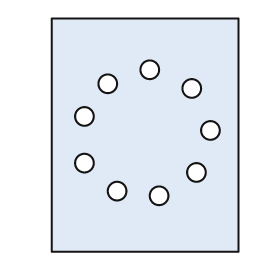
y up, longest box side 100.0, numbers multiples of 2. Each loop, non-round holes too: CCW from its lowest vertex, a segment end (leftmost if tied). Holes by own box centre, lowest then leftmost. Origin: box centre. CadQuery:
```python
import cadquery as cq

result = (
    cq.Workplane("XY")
    .moveTo(-40.0, -50.0)
    .lineTo(40.0, -50.0)
    .lineTo(40.0, 50.0)
    .lineTo(-40.0, 50.0)
    .close()
    .moveTo(6.0, -26.0)
    .circle(4.0)
    .moveTo(-12.0, -24.0)
    .circle(4.0)
    .moveTo(22.0, -16.0)
    .circle(4.0)
    .moveTo(-26.0, -12.0)
    .circle(4.0)
    .moveTo(28.0, 2.0)
    .circle(4.0)
    .moveTo(-26.0, 8.0)
    .circle(4.0)
    .moveTo(20.0, 20.0)
    .circle(4.0)
    .moveTo(-16.0, 22.0)
    .circle(4.0)
    .moveTo(2.0, 28.0)
    .circle(4.0)
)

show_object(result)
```